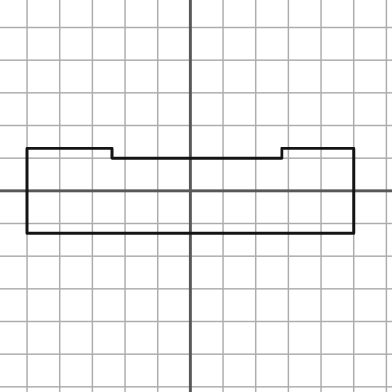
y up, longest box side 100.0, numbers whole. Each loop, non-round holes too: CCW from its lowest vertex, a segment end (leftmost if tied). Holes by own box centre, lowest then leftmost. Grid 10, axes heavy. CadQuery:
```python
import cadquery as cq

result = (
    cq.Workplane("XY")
    .moveTo(-50.0, -13.0)
    .lineTo(50.0, -13.0)
    .lineTo(50.0, 13.0)
    .lineTo(28.0, 13.0)
    .lineTo(28.0, 10.0)
    .lineTo(-24.0, 10.0)
    .lineTo(-24.0, 13.0)
    .lineTo(-50.0, 13.0)
    .close()
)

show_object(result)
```